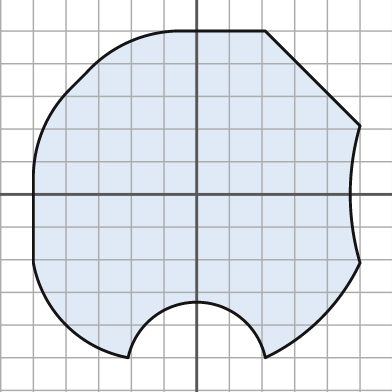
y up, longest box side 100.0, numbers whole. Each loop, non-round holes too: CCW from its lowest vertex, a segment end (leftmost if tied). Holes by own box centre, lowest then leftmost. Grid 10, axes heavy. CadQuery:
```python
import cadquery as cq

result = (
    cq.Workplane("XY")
    .moveTo(-21.0, -50.0)
    .threePointArc((0.0, -33.0), (21.0, -50.0))
    .threePointArc((38.0, -38.0), (50.0, -21.0))
    .threePointArc((47.0, 0.0), (50.0, 21.0))
    .lineTo(21.0, 50.0)
    .lineTo(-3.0, 50.0)
    .threePointArc((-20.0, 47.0), (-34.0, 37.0))
    .lineTo(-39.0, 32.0)
    .threePointArc((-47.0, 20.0), (-50.0, 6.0))
    .lineTo(-50.0, -21.0)
    .threePointArc((-40.0, -40.0), (-21.0, -50.0))
    .close()
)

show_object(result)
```